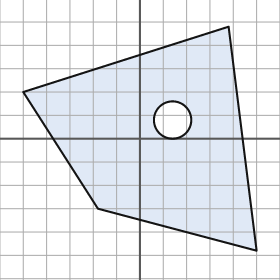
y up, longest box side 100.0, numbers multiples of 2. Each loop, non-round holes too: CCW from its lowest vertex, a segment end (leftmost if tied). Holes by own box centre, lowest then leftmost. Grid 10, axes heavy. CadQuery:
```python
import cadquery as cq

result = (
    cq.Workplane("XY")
    .moveTo(50.0, -48.0)
    .lineTo(38.0, 48.0)
    .lineTo(-50.0, 20.0)
    .lineTo(-18.0, -30.0)
    .close()
    .moveTo(14.0, 8.0)
    .circle(8.0)
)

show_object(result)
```